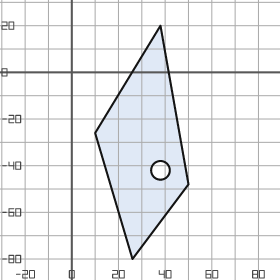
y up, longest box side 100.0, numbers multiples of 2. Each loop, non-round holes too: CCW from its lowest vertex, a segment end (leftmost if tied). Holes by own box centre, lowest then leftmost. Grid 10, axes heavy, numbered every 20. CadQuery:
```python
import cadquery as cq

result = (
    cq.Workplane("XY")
    .moveTo(26.0, -80.0)
    .lineTo(50.0, -48.0)
    .lineTo(38.0, 20.0)
    .lineTo(10.0, -26.0)
    .close()
    .moveTo(38.0, -42.0)
    .circle(4.0)
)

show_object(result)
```